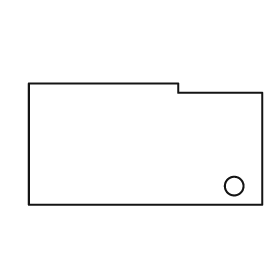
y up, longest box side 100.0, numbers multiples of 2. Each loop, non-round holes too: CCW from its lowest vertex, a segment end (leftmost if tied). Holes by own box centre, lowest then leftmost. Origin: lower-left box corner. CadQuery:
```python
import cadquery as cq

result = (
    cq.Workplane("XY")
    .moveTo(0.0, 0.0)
    .lineTo(100.0, 0.0)
    .lineTo(100.0, 48.0)
    .lineTo(64.0, 48.0)
    .lineTo(64.0, 52.0)
    .lineTo(0.0, 52.0)
    .close()
    .moveTo(88.0, 8.0)
    .circle(4.0)
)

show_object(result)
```